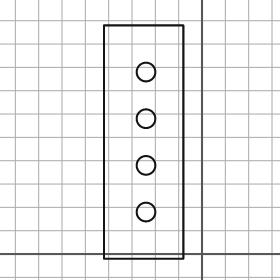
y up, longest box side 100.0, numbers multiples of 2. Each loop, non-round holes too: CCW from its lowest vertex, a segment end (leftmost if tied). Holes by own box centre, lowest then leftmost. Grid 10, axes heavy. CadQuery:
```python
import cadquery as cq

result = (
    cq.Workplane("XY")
    .moveTo(-42.0, -2.0)
    .lineTo(-8.0, -2.0)
    .lineTo(-8.0, 98.0)
    .lineTo(-42.0, 98.0)
    .close()
    .moveTo(-24.0, 18.0)
    .circle(4.0)
    .moveTo(-24.0, 38.0)
    .circle(4.0)
    .moveTo(-24.0, 58.0)
    .circle(4.0)
    .moveTo(-24.0, 78.0)
    .circle(4.0)
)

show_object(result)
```